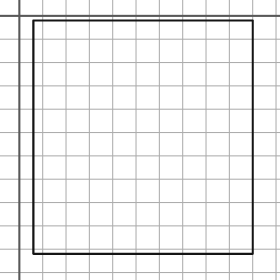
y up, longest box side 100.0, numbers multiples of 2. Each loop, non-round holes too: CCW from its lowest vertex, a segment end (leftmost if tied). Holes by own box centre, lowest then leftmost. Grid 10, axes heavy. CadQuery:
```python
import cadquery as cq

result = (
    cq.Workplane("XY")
    .moveTo(6.0, -102.0)
    .lineTo(100.0, -102.0)
    .lineTo(100.0, -2.0)
    .lineTo(6.0, -2.0)
    .close()
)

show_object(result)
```